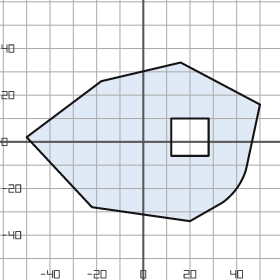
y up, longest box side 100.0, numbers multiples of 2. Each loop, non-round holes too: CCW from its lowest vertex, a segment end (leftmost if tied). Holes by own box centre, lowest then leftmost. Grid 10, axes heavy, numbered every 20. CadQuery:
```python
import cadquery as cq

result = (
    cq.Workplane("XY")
    .moveTo(20.0, -34.0)
    .lineTo(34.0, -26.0)
    .threePointArc((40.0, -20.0), (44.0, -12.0))
    .lineTo(50.0, 16.0)
    .lineTo(16.0, 34.0)
    .lineTo(-18.0, 26.0)
    .lineTo(-50.0, 2.0)
    .lineTo(-22.0, -28.0)
    .close()
    .moveTo(12.0, -6.0)
    .lineTo(28.0, -6.0)
    .lineTo(28.0, 10.0)
    .lineTo(12.0, 10.0)
    .close()
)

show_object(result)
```